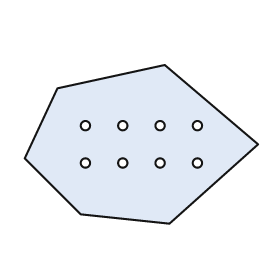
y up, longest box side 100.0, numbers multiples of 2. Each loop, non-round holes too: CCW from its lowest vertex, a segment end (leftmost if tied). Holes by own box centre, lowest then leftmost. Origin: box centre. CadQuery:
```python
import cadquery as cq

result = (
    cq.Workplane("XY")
    .moveTo(12.0, -34.0)
    .lineTo(50.0, 0.0)
    .lineTo(10.0, 34.0)
    .lineTo(-36.0, 24.0)
    .lineTo(-50.0, -6.0)
    .lineTo(-26.0, -30.0)
    .close()
    .moveTo(-24.0, -8.0)
    .circle(2.0)
    .moveTo(-8.0, -8.0)
    .circle(2.0)
    .moveTo(8.0, -8.0)
    .circle(2.0)
    .moveTo(24.0, -8.0)
    .circle(2.0)
    .moveTo(-24.0, 8.0)
    .circle(2.0)
    .moveTo(-8.0, 8.0)
    .circle(2.0)
    .moveTo(8.0, 8.0)
    .circle(2.0)
    .moveTo(24.0, 8.0)
    .circle(2.0)
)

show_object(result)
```